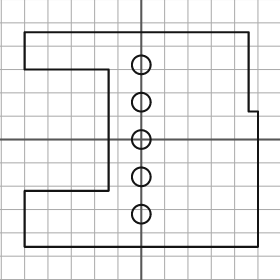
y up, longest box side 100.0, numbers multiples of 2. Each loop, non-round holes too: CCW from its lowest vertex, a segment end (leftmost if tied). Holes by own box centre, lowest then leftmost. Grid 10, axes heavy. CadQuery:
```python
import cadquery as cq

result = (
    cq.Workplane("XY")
    .moveTo(-50.0, -46.0)
    .lineTo(50.0, -46.0)
    .lineTo(50.0, 12.0)
    .lineTo(46.0, 12.0)
    .lineTo(46.0, 46.0)
    .lineTo(-50.0, 46.0)
    .lineTo(-50.0, 30.0)
    .lineTo(-14.0, 30.0)
    .lineTo(-14.0, -22.0)
    .lineTo(-50.0, -22.0)
    .close()
    .moveTo(0.0, -32.0)
    .circle(4.0)
    .moveTo(0.0, -16.0)
    .circle(4.0)
    .moveTo(0.0, 0.0)
    .circle(4.0)
    .moveTo(0.0, 16.0)
    .circle(4.0)
    .moveTo(0.0, 32.0)
    .circle(4.0)
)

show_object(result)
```